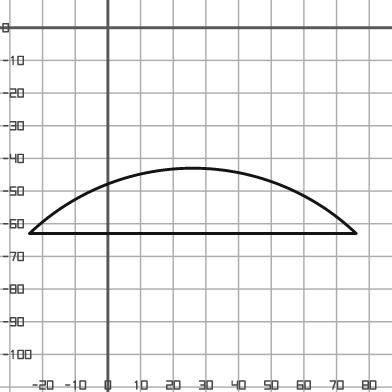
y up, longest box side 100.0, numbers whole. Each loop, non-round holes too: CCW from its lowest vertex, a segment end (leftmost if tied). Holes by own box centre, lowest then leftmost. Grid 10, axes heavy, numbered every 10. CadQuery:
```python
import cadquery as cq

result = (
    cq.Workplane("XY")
    .moveTo(-24.0, -63.0)
    .lineTo(76.0, -63.0)
    .threePointArc((26.0, -43.0), (-24.0, -63.0))
    .close()
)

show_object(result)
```